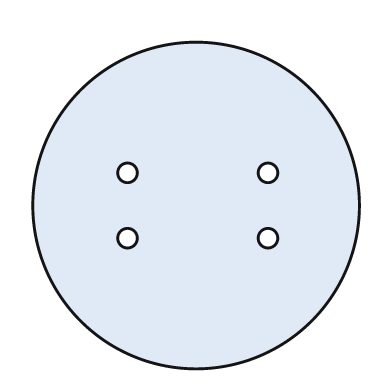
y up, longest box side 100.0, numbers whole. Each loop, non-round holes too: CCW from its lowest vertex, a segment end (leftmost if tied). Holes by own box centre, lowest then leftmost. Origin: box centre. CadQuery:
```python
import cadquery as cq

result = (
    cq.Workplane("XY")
    .moveTo(0.0, 0.0)
    .circle(50.0)
    .moveTo(-21.0, -10.0)
    .circle(3.0)
    .moveTo(22.0, -10.0)
    .circle(3.0)
    .moveTo(-21.0, 10.0)
    .circle(3.0)
    .moveTo(22.0, 10.0)
    .circle(3.0)
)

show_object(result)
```